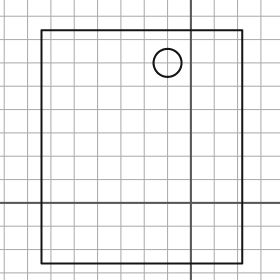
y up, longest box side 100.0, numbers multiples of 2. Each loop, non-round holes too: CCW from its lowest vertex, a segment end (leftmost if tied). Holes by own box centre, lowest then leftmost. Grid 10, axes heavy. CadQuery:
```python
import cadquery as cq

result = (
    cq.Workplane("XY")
    .moveTo(-64.0, -26.0)
    .lineTo(22.0, -26.0)
    .lineTo(22.0, 74.0)
    .lineTo(-64.0, 74.0)
    .close()
    .moveTo(-10.0, 60.0)
    .circle(6.0)
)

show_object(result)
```